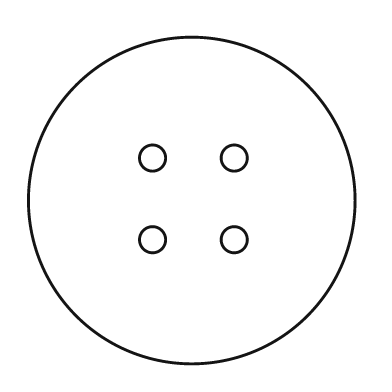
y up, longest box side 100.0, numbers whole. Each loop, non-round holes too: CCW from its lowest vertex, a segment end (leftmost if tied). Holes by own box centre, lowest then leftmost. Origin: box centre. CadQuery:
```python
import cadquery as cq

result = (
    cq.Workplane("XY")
    .moveTo(0.0, 0.0)
    .circle(50.0)
    .moveTo(-12.0, -12.0)
    .circle(4.0)
    .moveTo(13.0, -12.0)
    .circle(4.0)
    .moveTo(-12.0, 13.0)
    .circle(4.0)
    .moveTo(13.0, 13.0)
    .circle(4.0)
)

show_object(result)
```